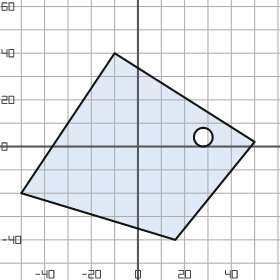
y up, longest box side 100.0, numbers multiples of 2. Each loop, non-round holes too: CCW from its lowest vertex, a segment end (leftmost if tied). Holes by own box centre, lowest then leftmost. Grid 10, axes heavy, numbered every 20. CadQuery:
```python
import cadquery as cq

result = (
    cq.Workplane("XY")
    .moveTo(16.0, -40.0)
    .lineTo(50.0, 2.0)
    .lineTo(-10.0, 40.0)
    .lineTo(-50.0, -20.0)
    .close()
    .moveTo(28.0, 4.0)
    .circle(4.0)
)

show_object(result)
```